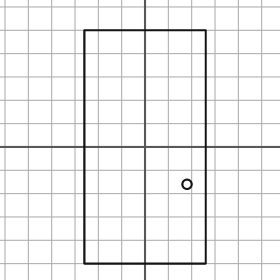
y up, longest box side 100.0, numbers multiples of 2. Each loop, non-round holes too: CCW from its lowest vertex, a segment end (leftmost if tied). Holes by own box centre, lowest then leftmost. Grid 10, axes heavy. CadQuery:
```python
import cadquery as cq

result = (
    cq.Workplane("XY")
    .moveTo(-26.0, -50.0)
    .lineTo(26.0, -50.0)
    .lineTo(26.0, 50.0)
    .lineTo(-26.0, 50.0)
    .close()
    .moveTo(18.0, -16.0)
    .circle(2.0)
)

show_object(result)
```